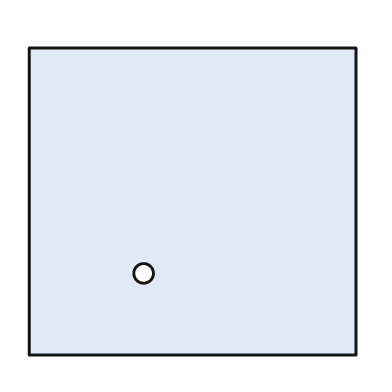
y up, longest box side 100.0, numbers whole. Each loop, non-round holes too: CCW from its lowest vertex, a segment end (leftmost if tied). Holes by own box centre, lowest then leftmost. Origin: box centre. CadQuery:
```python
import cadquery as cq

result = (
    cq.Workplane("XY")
    .moveTo(-50.0, -47.0)
    .lineTo(50.0, -47.0)
    .lineTo(50.0, 47.0)
    .lineTo(-50.0, 47.0)
    .close()
    .moveTo(-15.0, -22.0)
    .circle(3.0)
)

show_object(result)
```